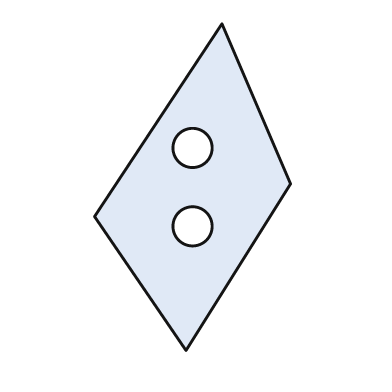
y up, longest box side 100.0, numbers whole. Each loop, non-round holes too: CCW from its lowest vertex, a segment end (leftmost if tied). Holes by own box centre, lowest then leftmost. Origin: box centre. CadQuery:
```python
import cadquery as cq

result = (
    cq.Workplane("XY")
    .moveTo(-2.0, -50.0)
    .lineTo(30.0, 1.0)
    .lineTo(9.0, 50.0)
    .lineTo(-30.0, -9.0)
    .close()
    .moveTo(0.0, -12.0)
    .circle(6.0)
    .moveTo(0.0, 12.0)
    .circle(6.0)
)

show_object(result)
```